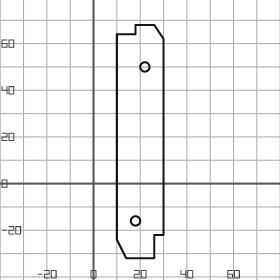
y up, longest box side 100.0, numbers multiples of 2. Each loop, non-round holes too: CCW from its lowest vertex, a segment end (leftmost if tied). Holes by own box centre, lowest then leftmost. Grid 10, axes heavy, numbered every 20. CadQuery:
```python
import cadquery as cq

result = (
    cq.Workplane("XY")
    .moveTo(14.0, -32.0)
    .lineTo(26.0, -32.0)
    .lineTo(26.0, -22.0)
    .lineTo(30.0, -22.0)
    .lineTo(30.0, 62.0)
    .lineTo(26.0, 68.0)
    .lineTo(18.0, 68.0)
    .lineTo(18.0, 64.0)
    .lineTo(10.0, 64.0)
    .lineTo(10.0, -24.0)
    .close()
    .moveTo(18.0, -16.0)
    .circle(2.0)
    .moveTo(22.0, 50.0)
    .circle(2.0)
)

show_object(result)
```